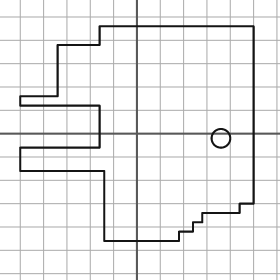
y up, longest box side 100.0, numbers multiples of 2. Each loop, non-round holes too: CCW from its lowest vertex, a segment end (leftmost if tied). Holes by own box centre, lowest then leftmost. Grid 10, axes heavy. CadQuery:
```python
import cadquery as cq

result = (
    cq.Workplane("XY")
    .moveTo(-14.0, -46.0)
    .lineTo(18.0, -46.0)
    .lineTo(18.0, -42.0)
    .lineTo(24.0, -42.0)
    .lineTo(24.0, -38.0)
    .lineTo(28.0, -38.0)
    .lineTo(28.0, -34.0)
    .lineTo(44.0, -34.0)
    .lineTo(44.0, -30.0)
    .lineTo(50.0, -30.0)
    .lineTo(50.0, 46.0)
    .lineTo(-16.0, 46.0)
    .lineTo(-16.0, 38.0)
    .lineTo(-34.0, 38.0)
    .lineTo(-34.0, 16.0)
    .lineTo(-50.0, 16.0)
    .lineTo(-50.0, 12.0)
    .lineTo(-16.0, 12.0)
    .lineTo(-16.0, -6.0)
    .lineTo(-50.0, -6.0)
    .lineTo(-50.0, -16.0)
    .lineTo(-14.0, -16.0)
    .close()
    .moveTo(36.0, -2.0)
    .circle(4.0)
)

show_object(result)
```